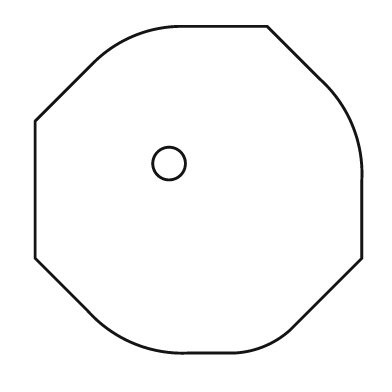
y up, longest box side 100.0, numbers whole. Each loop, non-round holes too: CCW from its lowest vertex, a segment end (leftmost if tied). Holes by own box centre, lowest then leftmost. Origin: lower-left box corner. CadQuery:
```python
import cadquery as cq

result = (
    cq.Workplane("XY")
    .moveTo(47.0, 0.0)
    .lineTo(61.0, 0.0)
    .threePointArc((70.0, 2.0), (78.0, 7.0))
    .lineTo(100.0, 29.0)
    .lineTo(100.0, 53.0)
    .threePointArc((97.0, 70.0), (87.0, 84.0))
    .lineTo(71.0, 100.0)
    .lineTo(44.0, 100.0)
    .threePointArc((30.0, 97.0), (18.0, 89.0))
    .lineTo(0.0, 71.0)
    .lineTo(0.0, 29.0)
    .lineTo(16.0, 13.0)
    .threePointArc((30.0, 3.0), (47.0, 0.0))
    .close()
    .moveTo(41.0, 58.0)
    .circle(5.0)
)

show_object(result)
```